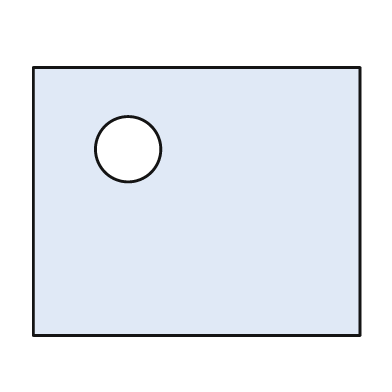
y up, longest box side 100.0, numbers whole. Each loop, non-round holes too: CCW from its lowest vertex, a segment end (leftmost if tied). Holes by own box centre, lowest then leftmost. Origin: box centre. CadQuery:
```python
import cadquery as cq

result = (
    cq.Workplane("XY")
    .moveTo(-50.0, -41.0)
    .lineTo(50.0, -41.0)
    .lineTo(50.0, 41.0)
    .lineTo(-50.0, 41.0)
    .close()
    .moveTo(-21.0, 16.0)
    .circle(10.0)
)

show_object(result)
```